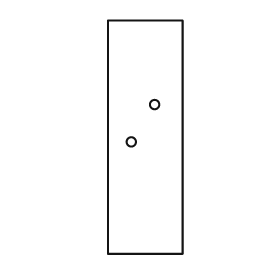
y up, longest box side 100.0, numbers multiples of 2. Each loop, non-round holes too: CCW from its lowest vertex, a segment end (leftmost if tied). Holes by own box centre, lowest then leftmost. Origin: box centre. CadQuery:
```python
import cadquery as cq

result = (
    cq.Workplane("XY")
    .moveTo(-16.0, -50.0)
    .lineTo(16.0, -50.0)
    .lineTo(16.0, 50.0)
    .lineTo(-16.0, 50.0)
    .close()
    .moveTo(-6.0, -2.0)
    .circle(2.0)
    .moveTo(4.0, 14.0)
    .circle(2.0)
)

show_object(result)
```